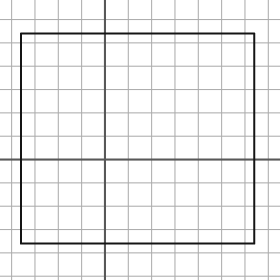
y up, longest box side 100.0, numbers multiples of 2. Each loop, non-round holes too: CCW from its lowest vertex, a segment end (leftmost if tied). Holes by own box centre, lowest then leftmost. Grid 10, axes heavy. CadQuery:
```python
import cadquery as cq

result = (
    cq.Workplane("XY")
    .moveTo(-36.0, -36.0)
    .lineTo(64.0, -36.0)
    .lineTo(64.0, 54.0)
    .lineTo(-36.0, 54.0)
    .close()
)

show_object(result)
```